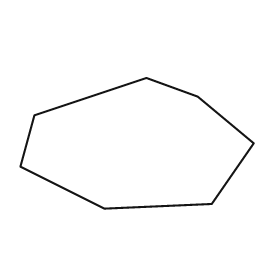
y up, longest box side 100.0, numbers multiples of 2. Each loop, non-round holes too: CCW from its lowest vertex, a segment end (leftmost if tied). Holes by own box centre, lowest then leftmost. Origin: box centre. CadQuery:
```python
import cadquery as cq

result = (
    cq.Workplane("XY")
    .moveTo(-14.0, -28.0)
    .lineTo(32.0, -26.0)
    .lineTo(50.0, 0.0)
    .lineTo(26.0, 20.0)
    .lineTo(4.0, 28.0)
    .lineTo(-44.0, 12.0)
    .lineTo(-50.0, -10.0)
    .close()
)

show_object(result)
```